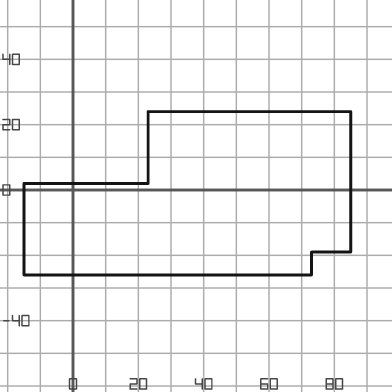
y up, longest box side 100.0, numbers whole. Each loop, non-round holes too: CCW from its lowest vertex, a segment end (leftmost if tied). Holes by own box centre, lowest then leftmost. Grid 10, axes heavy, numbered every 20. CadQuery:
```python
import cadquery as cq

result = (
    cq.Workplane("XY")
    .moveTo(-15.0, -26.0)
    .lineTo(73.0, -26.0)
    .lineTo(73.0, -19.0)
    .lineTo(85.0, -19.0)
    .lineTo(85.0, 24.0)
    .lineTo(23.0, 24.0)
    .lineTo(23.0, 2.0)
    .lineTo(-15.0, 2.0)
    .close()
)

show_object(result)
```